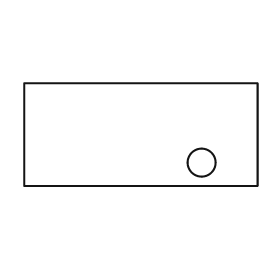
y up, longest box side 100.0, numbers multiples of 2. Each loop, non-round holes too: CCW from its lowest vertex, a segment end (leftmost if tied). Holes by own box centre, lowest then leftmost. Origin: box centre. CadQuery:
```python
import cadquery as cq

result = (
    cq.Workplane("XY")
    .moveTo(-50.0, -22.0)
    .lineTo(50.0, -22.0)
    .lineTo(50.0, 22.0)
    .lineTo(-50.0, 22.0)
    .close()
    .moveTo(26.0, -12.0)
    .circle(6.0)
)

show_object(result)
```